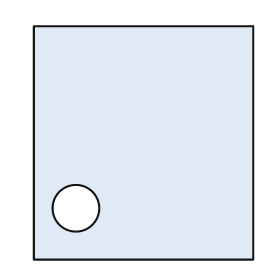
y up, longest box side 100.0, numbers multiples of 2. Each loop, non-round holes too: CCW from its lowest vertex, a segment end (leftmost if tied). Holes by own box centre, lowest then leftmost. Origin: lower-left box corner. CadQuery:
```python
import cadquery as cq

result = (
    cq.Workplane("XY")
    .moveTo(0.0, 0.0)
    .lineTo(94.0, 0.0)
    .lineTo(94.0, 100.0)
    .lineTo(0.0, 100.0)
    .close()
    .moveTo(18.0, 22.0)
    .circle(10.0)
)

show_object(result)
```